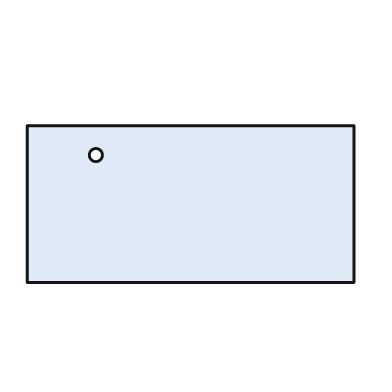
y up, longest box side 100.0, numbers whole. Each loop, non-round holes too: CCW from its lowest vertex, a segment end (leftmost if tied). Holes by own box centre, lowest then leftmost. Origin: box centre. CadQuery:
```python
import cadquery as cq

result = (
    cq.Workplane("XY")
    .moveTo(-50.0, -24.0)
    .lineTo(50.0, -24.0)
    .lineTo(50.0, 24.0)
    .lineTo(-50.0, 24.0)
    .close()
    .moveTo(-29.0, 15.0)
    .circle(2.0)
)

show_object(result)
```